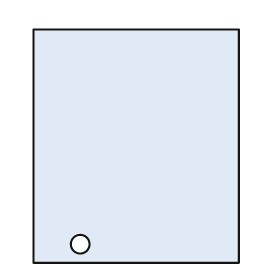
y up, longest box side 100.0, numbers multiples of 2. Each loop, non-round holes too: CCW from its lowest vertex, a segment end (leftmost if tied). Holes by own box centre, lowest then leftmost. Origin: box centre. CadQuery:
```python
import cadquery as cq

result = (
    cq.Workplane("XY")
    .moveTo(-44.0, -50.0)
    .lineTo(44.0, -50.0)
    .lineTo(44.0, 50.0)
    .lineTo(-44.0, 50.0)
    .close()
    .moveTo(-24.0, -42.0)
    .circle(4.0)
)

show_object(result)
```